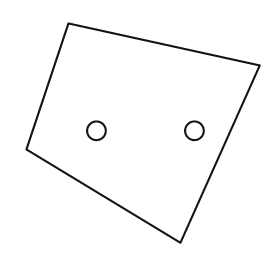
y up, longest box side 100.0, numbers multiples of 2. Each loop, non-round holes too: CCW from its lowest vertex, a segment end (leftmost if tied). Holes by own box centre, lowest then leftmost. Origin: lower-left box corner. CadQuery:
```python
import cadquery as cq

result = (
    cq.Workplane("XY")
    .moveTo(66.0, 0.0)
    .lineTo(100.0, 76.0)
    .lineTo(18.0, 94.0)
    .lineTo(0.0, 40.0)
    .close()
    .moveTo(30.0, 48.0)
    .circle(4.0)
    .moveTo(72.0, 48.0)
    .circle(4.0)
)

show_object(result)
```